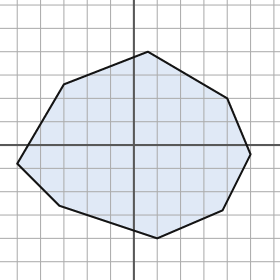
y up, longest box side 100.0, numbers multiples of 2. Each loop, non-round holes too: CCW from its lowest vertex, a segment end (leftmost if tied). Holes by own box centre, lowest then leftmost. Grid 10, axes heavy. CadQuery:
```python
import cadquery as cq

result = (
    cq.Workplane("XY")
    .moveTo(10.0, -40.0)
    .lineTo(38.0, -28.0)
    .lineTo(50.0, -4.0)
    .lineTo(40.0, 20.0)
    .lineTo(6.0, 40.0)
    .lineTo(-30.0, 26.0)
    .lineTo(-50.0, -8.0)
    .lineTo(-32.0, -26.0)
    .close()
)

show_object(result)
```